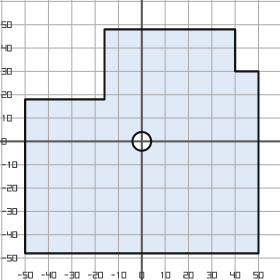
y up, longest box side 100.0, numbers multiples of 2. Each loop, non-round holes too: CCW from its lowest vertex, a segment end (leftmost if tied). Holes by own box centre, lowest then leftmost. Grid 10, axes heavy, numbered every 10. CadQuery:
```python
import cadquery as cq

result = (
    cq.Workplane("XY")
    .moveTo(-50.0, -48.0)
    .lineTo(50.0, -48.0)
    .lineTo(50.0, 30.0)
    .lineTo(40.0, 30.0)
    .lineTo(40.0, 48.0)
    .lineTo(-16.0, 48.0)
    .lineTo(-16.0, 18.0)
    .lineTo(-50.0, 18.0)
    .close()
    .moveTo(0.0, 0.0)
    .circle(4.0)
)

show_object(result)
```